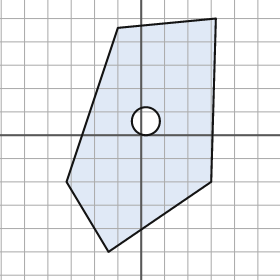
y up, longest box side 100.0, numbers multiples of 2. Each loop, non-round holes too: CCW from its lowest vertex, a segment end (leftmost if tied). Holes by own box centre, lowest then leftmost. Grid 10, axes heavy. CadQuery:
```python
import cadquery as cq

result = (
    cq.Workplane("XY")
    .moveTo(-14.0, -50.0)
    .lineTo(30.0, -20.0)
    .lineTo(32.0, 50.0)
    .lineTo(-10.0, 46.0)
    .lineTo(-32.0, -20.0)
    .close()
    .moveTo(2.0, 6.0)
    .circle(6.0)
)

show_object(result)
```